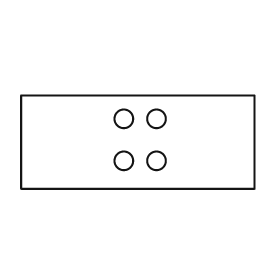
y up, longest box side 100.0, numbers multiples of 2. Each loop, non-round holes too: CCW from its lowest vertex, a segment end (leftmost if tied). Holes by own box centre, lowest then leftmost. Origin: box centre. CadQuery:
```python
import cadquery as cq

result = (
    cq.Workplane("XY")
    .moveTo(-50.0, -20.0)
    .lineTo(50.0, -20.0)
    .lineTo(50.0, 20.0)
    .lineTo(-50.0, 20.0)
    .close()
    .moveTo(-6.0, -8.0)
    .circle(4.0)
    .moveTo(8.0, -8.0)
    .circle(4.0)
    .moveTo(-6.0, 10.0)
    .circle(4.0)
    .moveTo(8.0, 10.0)
    .circle(4.0)
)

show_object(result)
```